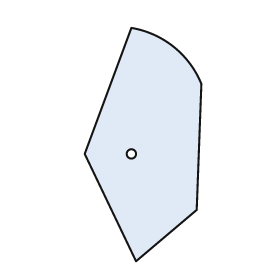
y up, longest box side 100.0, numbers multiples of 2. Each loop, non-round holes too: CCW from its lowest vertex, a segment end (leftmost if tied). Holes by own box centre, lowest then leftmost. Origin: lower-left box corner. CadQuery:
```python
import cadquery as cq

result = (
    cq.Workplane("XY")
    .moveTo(22.0, 0.0)
    .lineTo(48.0, 22.0)
    .lineTo(50.0, 76.0)
    .threePointArc((38.0, 92.0), (20.0, 100.0))
    .lineTo(0.0, 46.0)
    .close()
    .moveTo(20.0, 46.0)
    .circle(2.0)
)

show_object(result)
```